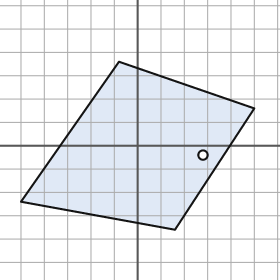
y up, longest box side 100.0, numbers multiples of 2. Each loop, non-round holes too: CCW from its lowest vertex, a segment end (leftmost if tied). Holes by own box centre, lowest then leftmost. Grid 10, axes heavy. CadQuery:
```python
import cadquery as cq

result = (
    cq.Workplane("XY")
    .moveTo(16.0, -36.0)
    .lineTo(50.0, 16.0)
    .lineTo(-8.0, 36.0)
    .lineTo(-50.0, -24.0)
    .close()
    .moveTo(28.0, -4.0)
    .circle(2.0)
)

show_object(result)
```